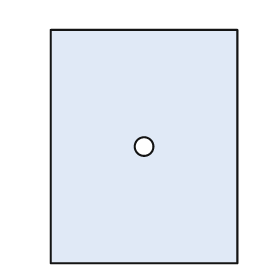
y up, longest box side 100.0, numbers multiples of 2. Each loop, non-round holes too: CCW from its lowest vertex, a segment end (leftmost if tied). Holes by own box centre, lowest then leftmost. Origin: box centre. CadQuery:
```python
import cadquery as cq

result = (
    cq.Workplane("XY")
    .moveTo(-40.0, -50.0)
    .lineTo(40.0, -50.0)
    .lineTo(40.0, 50.0)
    .lineTo(-40.0, 50.0)
    .close()
    .moveTo(0.0, 0.0)
    .circle(4.0)
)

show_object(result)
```